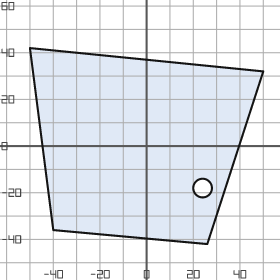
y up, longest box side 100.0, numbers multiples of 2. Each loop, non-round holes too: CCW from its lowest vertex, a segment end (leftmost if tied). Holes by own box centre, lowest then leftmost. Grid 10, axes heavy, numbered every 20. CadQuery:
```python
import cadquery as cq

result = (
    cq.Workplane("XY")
    .moveTo(26.0, -42.0)
    .lineTo(50.0, 32.0)
    .lineTo(-50.0, 42.0)
    .lineTo(-40.0, -36.0)
    .close()
    .moveTo(24.0, -18.0)
    .circle(4.0)
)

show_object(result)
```